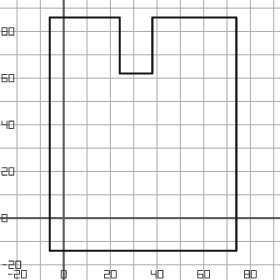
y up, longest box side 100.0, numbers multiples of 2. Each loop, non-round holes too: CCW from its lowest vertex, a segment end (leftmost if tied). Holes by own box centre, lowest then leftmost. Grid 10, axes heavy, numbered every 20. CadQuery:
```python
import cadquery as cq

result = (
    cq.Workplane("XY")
    .moveTo(-6.0, -14.0)
    .lineTo(74.0, -14.0)
    .lineTo(74.0, 86.0)
    .lineTo(38.0, 86.0)
    .lineTo(38.0, 62.0)
    .lineTo(24.0, 62.0)
    .lineTo(24.0, 86.0)
    .lineTo(-6.0, 86.0)
    .close()
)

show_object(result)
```